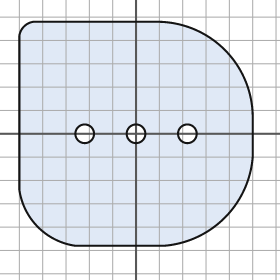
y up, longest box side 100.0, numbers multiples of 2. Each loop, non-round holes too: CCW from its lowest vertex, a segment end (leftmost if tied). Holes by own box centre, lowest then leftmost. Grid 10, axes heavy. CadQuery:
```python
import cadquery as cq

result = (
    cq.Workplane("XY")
    .moveTo(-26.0, -48.0)
    .lineTo(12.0, -48.0)
    .threePointArc((38.0, -36.0), (50.0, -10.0))
    .lineTo(50.0, 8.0)
    .threePointArc((38.0, 36.0), (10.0, 48.0))
    .lineTo(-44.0, 48.0)
    .threePointArc((-48.0, 46.0), (-50.0, 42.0))
    .lineTo(-50.0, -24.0)
    .threePointArc((-42.0, -40.0), (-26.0, -48.0))
    .close()
    .moveTo(-22.0, 0.0)
    .circle(4.0)
    .moveTo(0.0, 0.0)
    .circle(4.0)
    .moveTo(22.0, 0.0)
    .circle(4.0)
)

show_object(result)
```